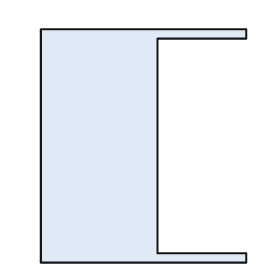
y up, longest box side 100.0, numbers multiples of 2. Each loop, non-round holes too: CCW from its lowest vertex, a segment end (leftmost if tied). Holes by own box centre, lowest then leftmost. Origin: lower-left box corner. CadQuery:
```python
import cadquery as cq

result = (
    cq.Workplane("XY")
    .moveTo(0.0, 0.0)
    .lineTo(88.0, 0.0)
    .lineTo(88.0, 4.0)
    .lineTo(50.0, 4.0)
    .lineTo(50.0, 96.0)
    .lineTo(88.0, 96.0)
    .lineTo(88.0, 100.0)
    .lineTo(0.0, 100.0)
    .close()
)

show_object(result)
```